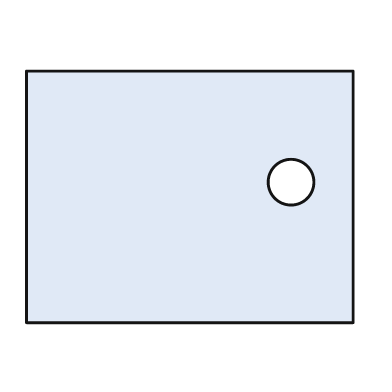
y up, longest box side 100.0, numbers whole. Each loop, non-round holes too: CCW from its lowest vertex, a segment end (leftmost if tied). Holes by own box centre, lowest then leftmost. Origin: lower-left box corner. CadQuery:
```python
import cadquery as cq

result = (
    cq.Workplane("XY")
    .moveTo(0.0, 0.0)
    .lineTo(100.0, 0.0)
    .lineTo(100.0, 77.0)
    .lineTo(0.0, 77.0)
    .close()
    .moveTo(81.0, 43.0)
    .circle(7.0)
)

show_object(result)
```